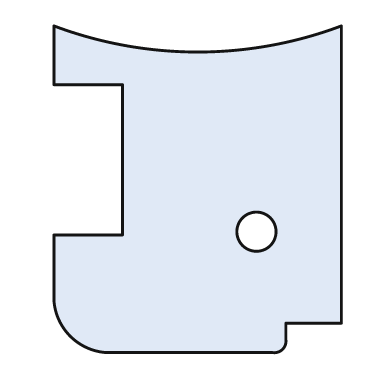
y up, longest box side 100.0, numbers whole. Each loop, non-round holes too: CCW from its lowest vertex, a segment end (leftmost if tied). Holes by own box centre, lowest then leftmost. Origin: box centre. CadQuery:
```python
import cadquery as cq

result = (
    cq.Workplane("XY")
    .moveTo(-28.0, -50.0)
    .lineTo(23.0, -50.0)
    .threePointArc((26.0, -49.0), (27.0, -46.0))
    .lineTo(27.0, -41.0)
    .lineTo(44.0, -41.0)
    .lineTo(44.0, 50.0)
    .threePointArc((0.0, 42.0), (-44.0, 50.0))
    .lineTo(-44.0, 32.0)
    .lineTo(-23.0, 32.0)
    .lineTo(-23.0, -14.0)
    .lineTo(-44.0, -14.0)
    .lineTo(-44.0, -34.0)
    .threePointArc((-39.0, -45.0), (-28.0, -50.0))
    .close()
    .moveTo(18.0, -13.0)
    .circle(6.0)
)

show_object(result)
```